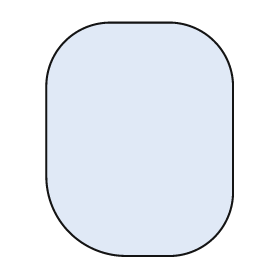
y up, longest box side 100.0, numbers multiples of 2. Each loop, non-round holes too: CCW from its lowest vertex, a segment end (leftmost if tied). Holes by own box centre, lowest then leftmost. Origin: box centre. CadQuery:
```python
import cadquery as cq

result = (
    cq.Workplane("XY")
    .moveTo(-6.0, -50.0)
    .lineTo(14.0, -50.0)
    .threePointArc((32.0, -42.0), (40.0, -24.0))
    .lineTo(40.0, 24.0)
    .threePointArc((32.0, 42.0), (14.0, 50.0))
    .lineTo(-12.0, 50.0)
    .threePointArc((-32.0, 42.0), (-40.0, 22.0))
    .lineTo(-40.0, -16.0)
    .threePointArc((-30.0, -40.0), (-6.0, -50.0))
    .close()
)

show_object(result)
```